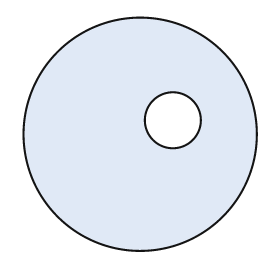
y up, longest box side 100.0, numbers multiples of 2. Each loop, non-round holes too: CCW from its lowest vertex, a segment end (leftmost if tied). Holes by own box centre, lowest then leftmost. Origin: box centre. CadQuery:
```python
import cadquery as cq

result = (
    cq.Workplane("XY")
    .moveTo(0.0, 0.0)
    .circle(50.0)
    .moveTo(14.0, 6.0)
    .circle(12.0)
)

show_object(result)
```